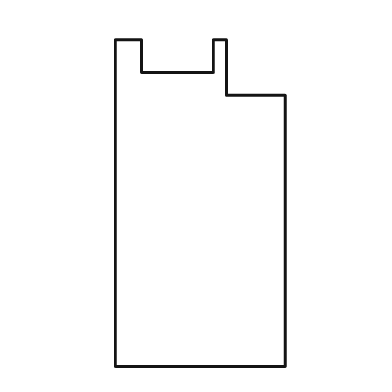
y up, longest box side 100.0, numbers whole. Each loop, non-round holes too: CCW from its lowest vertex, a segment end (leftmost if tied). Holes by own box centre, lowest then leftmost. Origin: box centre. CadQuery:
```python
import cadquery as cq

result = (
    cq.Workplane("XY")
    .moveTo(-26.0, -50.0)
    .lineTo(26.0, -50.0)
    .lineTo(26.0, 33.0)
    .lineTo(8.0, 33.0)
    .lineTo(8.0, 50.0)
    .lineTo(4.0, 50.0)
    .lineTo(4.0, 40.0)
    .lineTo(-18.0, 40.0)
    .lineTo(-18.0, 50.0)
    .lineTo(-26.0, 50.0)
    .close()
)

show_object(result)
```